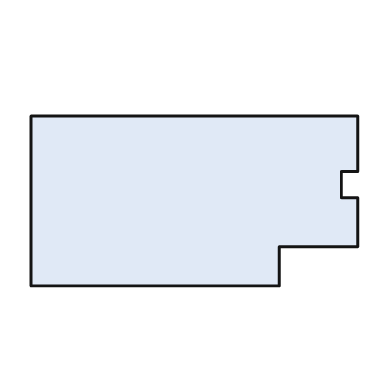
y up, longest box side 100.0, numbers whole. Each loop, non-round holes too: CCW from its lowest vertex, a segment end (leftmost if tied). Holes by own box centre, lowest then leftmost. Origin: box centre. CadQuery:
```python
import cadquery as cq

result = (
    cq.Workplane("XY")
    .moveTo(-50.0, -26.0)
    .lineTo(26.0, -26.0)
    .lineTo(26.0, -14.0)
    .lineTo(50.0, -14.0)
    .lineTo(50.0, 1.0)
    .lineTo(45.0, 1.0)
    .lineTo(45.0, 9.0)
    .lineTo(50.0, 9.0)
    .lineTo(50.0, 26.0)
    .lineTo(-50.0, 26.0)
    .close()
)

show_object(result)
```